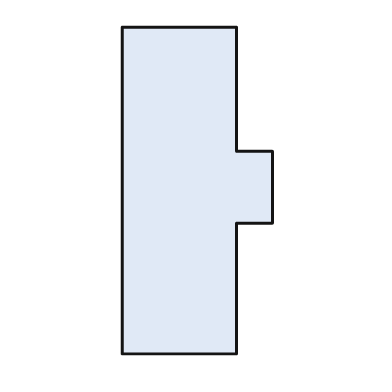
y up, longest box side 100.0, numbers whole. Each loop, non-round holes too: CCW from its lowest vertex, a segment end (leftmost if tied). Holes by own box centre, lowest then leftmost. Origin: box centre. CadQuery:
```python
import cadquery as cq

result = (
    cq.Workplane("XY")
    .moveTo(-23.0, -50.0)
    .lineTo(12.0, -50.0)
    .lineTo(12.0, -10.0)
    .lineTo(23.0, -10.0)
    .lineTo(23.0, 12.0)
    .lineTo(12.0, 12.0)
    .lineTo(12.0, 50.0)
    .lineTo(-23.0, 50.0)
    .close()
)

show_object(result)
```